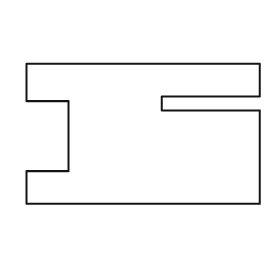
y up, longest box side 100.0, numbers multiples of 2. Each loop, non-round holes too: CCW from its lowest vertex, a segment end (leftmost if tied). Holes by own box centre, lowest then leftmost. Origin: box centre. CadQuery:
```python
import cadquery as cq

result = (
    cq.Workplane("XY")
    .moveTo(-50.0, -30.0)
    .lineTo(50.0, -30.0)
    .lineTo(50.0, 10.0)
    .lineTo(8.0, 10.0)
    .lineTo(8.0, 16.0)
    .lineTo(50.0, 16.0)
    .lineTo(50.0, 30.0)
    .lineTo(-50.0, 30.0)
    .lineTo(-50.0, 14.0)
    .lineTo(-32.0, 14.0)
    .lineTo(-32.0, -16.0)
    .lineTo(-50.0, -16.0)
    .close()
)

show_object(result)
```